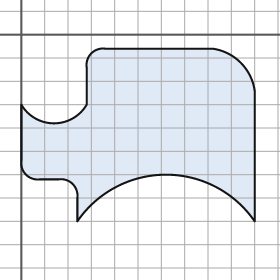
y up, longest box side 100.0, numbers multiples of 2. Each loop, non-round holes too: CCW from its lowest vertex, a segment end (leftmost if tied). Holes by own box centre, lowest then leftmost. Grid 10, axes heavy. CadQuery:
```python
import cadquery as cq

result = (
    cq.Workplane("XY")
    .moveTo(24.0, -80.0)
    .threePointArc((62.0, -60.0), (100.0, -80.0))
    .lineTo(100.0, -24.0)
    .threePointArc((94.0, -12.0), (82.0, -6.0))
    .lineTo(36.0, -6.0)
    .threePointArc((30.0, -8.0), (28.0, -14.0))
    .lineTo(28.0, -30.0)
    .threePointArc((14.0, -38.0), (0.0, -30.0))
    .lineTo(0.0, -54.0)
    .threePointArc((2.0, -60.0), (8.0, -62.0))
    .lineTo(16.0, -62.0)
    .threePointArc((22.0, -64.0), (24.0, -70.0))
    .close()
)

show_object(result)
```